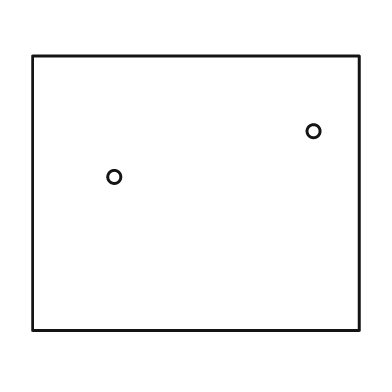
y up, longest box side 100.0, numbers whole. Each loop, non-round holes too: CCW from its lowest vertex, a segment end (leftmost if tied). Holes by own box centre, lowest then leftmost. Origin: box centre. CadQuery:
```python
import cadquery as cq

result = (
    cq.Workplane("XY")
    .moveTo(-50.0, -42.0)
    .lineTo(50.0, -42.0)
    .lineTo(50.0, 42.0)
    .lineTo(-50.0, 42.0)
    .close()
    .moveTo(-25.0, 5.0)
    .circle(2.0)
    .moveTo(36.0, 19.0)
    .circle(2.0)
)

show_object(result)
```